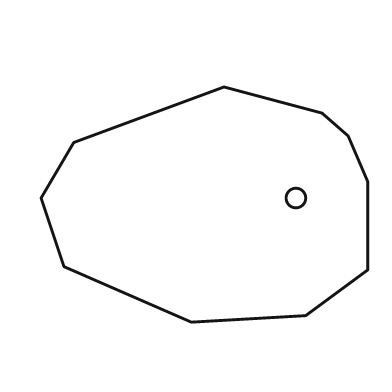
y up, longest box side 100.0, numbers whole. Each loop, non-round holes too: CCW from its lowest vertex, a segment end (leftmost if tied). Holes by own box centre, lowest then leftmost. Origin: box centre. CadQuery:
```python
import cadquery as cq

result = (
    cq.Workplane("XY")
    .moveTo(-4.0, -36.0)
    .lineTo(31.0, -34.0)
    .lineTo(50.0, -20.0)
    .lineTo(50.0, 7.0)
    .lineTo(44.0, 21.0)
    .lineTo(36.0, 28.0)
    .lineTo(6.0, 36.0)
    .lineTo(-40.0, 19.0)
    .lineTo(-50.0, 2.0)
    .lineTo(-43.0, -19.0)
    .close()
    .moveTo(28.0, 2.0)
    .circle(3.0)
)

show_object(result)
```